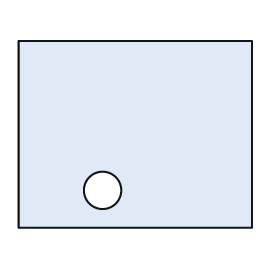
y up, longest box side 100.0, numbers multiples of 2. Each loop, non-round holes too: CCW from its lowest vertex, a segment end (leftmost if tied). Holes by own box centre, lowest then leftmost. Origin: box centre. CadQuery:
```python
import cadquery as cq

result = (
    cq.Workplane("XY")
    .moveTo(-50.0, -40.0)
    .lineTo(50.0, -40.0)
    .lineTo(50.0, 40.0)
    .lineTo(-50.0, 40.0)
    .close()
    .moveTo(-14.0, -24.0)
    .circle(8.0)
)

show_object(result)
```